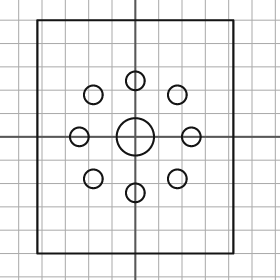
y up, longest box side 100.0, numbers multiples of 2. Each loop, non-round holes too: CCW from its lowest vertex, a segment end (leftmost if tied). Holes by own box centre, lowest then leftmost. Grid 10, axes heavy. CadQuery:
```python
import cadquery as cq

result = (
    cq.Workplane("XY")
    .moveTo(-42.0, -50.0)
    .lineTo(42.0, -50.0)
    .lineTo(42.0, 50.0)
    .lineTo(-42.0, 50.0)
    .close()
    .moveTo(0.0, -24.0)
    .circle(4.0)
    .moveTo(-18.0, -18.0)
    .circle(4.0)
    .moveTo(18.0, -18.0)
    .circle(4.0)
    .moveTo(-24.0, 0.0)
    .circle(4.0)
    .moveTo(0.0, 0.0)
    .circle(8.0)
    .moveTo(24.0, 0.0)
    .circle(4.0)
    .moveTo(-18.0, 18.0)
    .circle(4.0)
    .moveTo(18.0, 18.0)
    .circle(4.0)
    .moveTo(0.0, 24.0)
    .circle(4.0)
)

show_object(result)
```